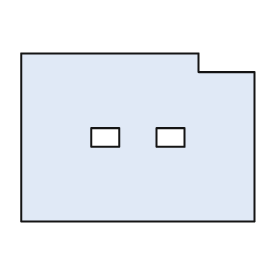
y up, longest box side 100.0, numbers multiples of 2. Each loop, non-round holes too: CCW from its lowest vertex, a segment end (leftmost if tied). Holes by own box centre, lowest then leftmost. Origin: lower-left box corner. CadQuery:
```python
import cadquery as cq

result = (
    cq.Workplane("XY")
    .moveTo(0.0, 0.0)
    .lineTo(100.0, 0.0)
    .lineTo(100.0, 64.0)
    .lineTo(76.0, 64.0)
    .lineTo(76.0, 72.0)
    .lineTo(0.0, 72.0)
    .close()
    .moveTo(30.0, 32.0)
    .lineTo(42.0, 32.0)
    .lineTo(42.0, 40.0)
    .lineTo(30.0, 40.0)
    .close()
    .moveTo(58.0, 32.0)
    .lineTo(70.0, 32.0)
    .lineTo(70.0, 40.0)
    .lineTo(58.0, 40.0)
    .close()
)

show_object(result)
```